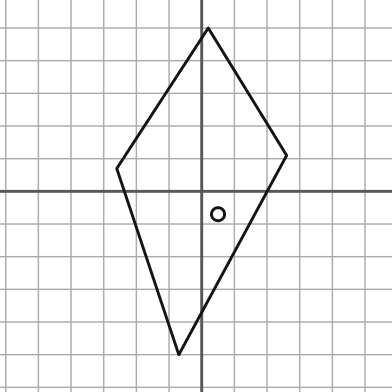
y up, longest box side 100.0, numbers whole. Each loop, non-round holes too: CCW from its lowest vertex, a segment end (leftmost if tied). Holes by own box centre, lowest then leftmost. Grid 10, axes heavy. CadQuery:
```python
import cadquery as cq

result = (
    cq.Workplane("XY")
    .moveTo(-7.0, -50.0)
    .lineTo(26.0, 11.0)
    .lineTo(2.0, 50.0)
    .lineTo(-26.0, 7.0)
    .close()
    .moveTo(5.0, -7.0)
    .circle(2.0)
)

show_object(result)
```